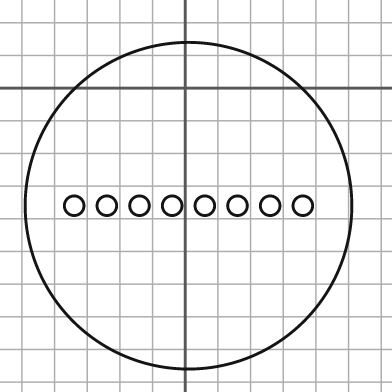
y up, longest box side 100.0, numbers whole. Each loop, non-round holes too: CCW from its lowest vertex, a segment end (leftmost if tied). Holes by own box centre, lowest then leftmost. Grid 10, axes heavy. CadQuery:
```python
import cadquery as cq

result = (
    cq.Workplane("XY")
    .moveTo(1.0, -36.0)
    .circle(50.0)
    .moveTo(-34.0, -36.0)
    .circle(3.0)
    .moveTo(-24.0, -36.0)
    .circle(3.0)
    .moveTo(-14.0, -36.0)
    .circle(3.0)
    .moveTo(-4.0, -36.0)
    .circle(3.0)
    .moveTo(6.0, -36.0)
    .circle(3.0)
    .moveTo(16.0, -36.0)
    .circle(3.0)
    .moveTo(26.0, -36.0)
    .circle(3.0)
    .moveTo(36.0, -36.0)
    .circle(3.0)
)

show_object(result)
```